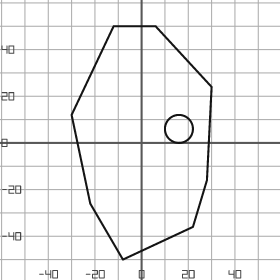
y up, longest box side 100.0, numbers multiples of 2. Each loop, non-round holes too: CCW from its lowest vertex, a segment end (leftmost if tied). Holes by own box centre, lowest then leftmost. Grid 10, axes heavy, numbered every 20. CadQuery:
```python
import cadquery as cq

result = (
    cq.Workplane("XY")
    .moveTo(-8.0, -50.0)
    .lineTo(22.0, -36.0)
    .lineTo(28.0, -16.0)
    .lineTo(30.0, 24.0)
    .lineTo(6.0, 50.0)
    .lineTo(-12.0, 50.0)
    .lineTo(-30.0, 12.0)
    .lineTo(-22.0, -26.0)
    .close()
    .moveTo(16.0, 6.0)
    .circle(6.0)
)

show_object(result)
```